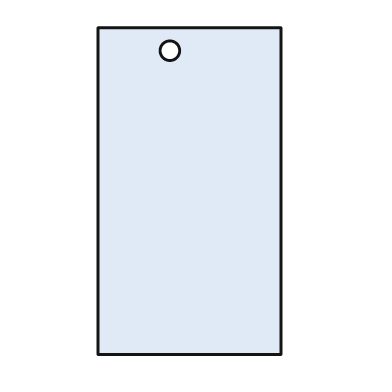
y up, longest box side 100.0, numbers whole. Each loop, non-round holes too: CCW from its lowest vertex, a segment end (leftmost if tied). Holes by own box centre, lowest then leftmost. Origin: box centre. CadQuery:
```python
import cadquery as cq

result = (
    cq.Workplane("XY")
    .moveTo(-28.0, -50.0)
    .lineTo(28.0, -50.0)
    .lineTo(28.0, 50.0)
    .lineTo(-28.0, 50.0)
    .close()
    .moveTo(-6.0, 43.0)
    .circle(3.0)
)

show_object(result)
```